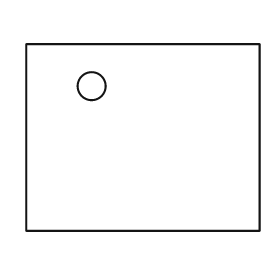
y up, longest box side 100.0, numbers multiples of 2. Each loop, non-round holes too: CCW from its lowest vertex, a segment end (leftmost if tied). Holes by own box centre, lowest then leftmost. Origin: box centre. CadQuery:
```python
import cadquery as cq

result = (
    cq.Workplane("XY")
    .moveTo(-50.0, -40.0)
    .lineTo(50.0, -40.0)
    .lineTo(50.0, 40.0)
    .lineTo(-50.0, 40.0)
    .close()
    .moveTo(-22.0, 22.0)
    .circle(6.0)
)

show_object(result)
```